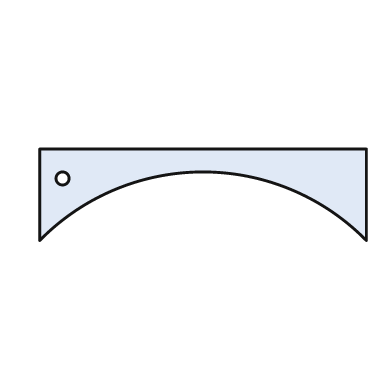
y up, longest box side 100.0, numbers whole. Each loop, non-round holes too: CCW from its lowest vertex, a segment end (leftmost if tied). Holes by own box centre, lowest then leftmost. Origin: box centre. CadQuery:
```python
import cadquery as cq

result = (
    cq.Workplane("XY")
    .moveTo(-50.0, -14.0)
    .threePointArc((0.0, 7.0), (50.0, -14.0))
    .lineTo(50.0, 14.0)
    .lineTo(-50.0, 14.0)
    .close()
    .moveTo(-43.0, 5.0)
    .circle(2.0)
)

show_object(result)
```